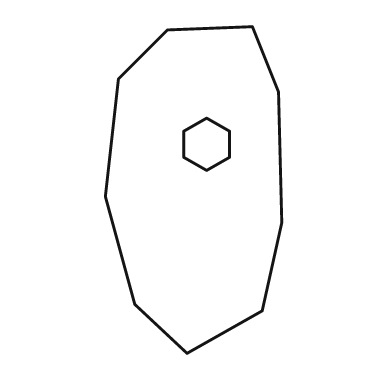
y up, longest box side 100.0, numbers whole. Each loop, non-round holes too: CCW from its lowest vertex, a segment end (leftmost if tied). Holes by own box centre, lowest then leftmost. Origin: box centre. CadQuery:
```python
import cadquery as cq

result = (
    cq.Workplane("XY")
    .moveTo(-2.0, -50.0)
    .lineTo(21.0, -37.0)
    .lineTo(27.0, -10.0)
    .lineTo(26.0, 30.0)
    .lineTo(18.0, 50.0)
    .lineTo(-8.0, 49.0)
    .lineTo(-23.0, 34.0)
    .lineTo(-27.0, -2.0)
    .lineTo(-18.0, -35.0)
    .close()
    .moveTo(4.0, 6.0)
    .lineTo(11.0, 10.0)
    .lineTo(11.0, 18.0)
    .lineTo(4.0, 22.0)
    .lineTo(-3.0, 18.0)
    .lineTo(-3.0, 10.0)
    .close()
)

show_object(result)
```